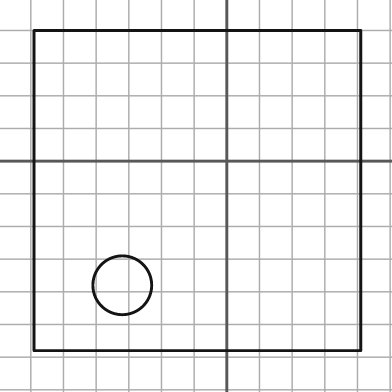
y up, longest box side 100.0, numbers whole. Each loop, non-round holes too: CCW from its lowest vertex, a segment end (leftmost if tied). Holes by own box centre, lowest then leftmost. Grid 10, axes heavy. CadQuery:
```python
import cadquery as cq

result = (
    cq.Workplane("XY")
    .moveTo(-59.0, -58.0)
    .lineTo(41.0, -58.0)
    .lineTo(41.0, 40.0)
    .lineTo(-59.0, 40.0)
    .close()
    .moveTo(-32.0, -38.0)
    .circle(9.0)
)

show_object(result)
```